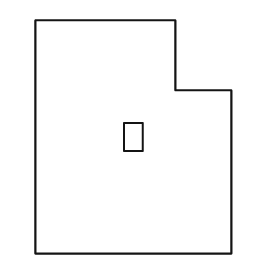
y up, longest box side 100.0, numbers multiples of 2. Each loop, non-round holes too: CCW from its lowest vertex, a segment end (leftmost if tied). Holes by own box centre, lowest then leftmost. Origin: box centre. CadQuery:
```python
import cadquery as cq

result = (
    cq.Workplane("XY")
    .moveTo(-42.0, -50.0)
    .lineTo(42.0, -50.0)
    .lineTo(42.0, 20.0)
    .lineTo(18.0, 20.0)
    .lineTo(18.0, 50.0)
    .lineTo(-42.0, 50.0)
    .close()
    .moveTo(-4.0, -6.0)
    .lineTo(4.0, -6.0)
    .lineTo(4.0, 6.0)
    .lineTo(-4.0, 6.0)
    .close()
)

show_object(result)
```